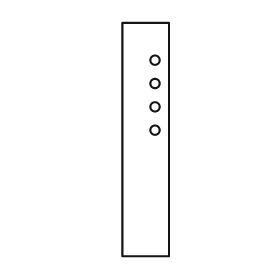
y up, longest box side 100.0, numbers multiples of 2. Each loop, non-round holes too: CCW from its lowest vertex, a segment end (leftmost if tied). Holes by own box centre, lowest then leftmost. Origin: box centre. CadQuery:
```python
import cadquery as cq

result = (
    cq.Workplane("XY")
    .moveTo(-10.0, -50.0)
    .lineTo(10.0, -50.0)
    .lineTo(10.0, 50.0)
    .lineTo(-10.0, 50.0)
    .close()
    .moveTo(4.0, 4.0)
    .circle(2.0)
    .moveTo(4.0, 14.0)
    .circle(2.0)
    .moveTo(4.0, 24.0)
    .circle(2.0)
    .moveTo(4.0, 34.0)
    .circle(2.0)
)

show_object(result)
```